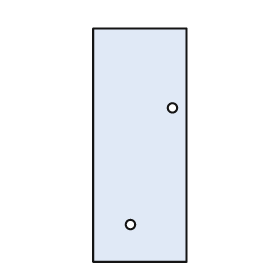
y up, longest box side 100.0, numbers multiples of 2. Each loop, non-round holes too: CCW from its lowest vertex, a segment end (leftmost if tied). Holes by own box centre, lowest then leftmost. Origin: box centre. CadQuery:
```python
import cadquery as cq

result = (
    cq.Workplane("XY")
    .moveTo(-20.0, -50.0)
    .lineTo(20.0, -50.0)
    .lineTo(20.0, 50.0)
    .lineTo(-20.0, 50.0)
    .close()
    .moveTo(-4.0, -34.0)
    .circle(2.0)
    .moveTo(14.0, 16.0)
    .circle(2.0)
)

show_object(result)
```